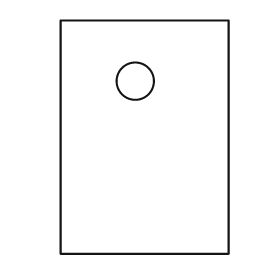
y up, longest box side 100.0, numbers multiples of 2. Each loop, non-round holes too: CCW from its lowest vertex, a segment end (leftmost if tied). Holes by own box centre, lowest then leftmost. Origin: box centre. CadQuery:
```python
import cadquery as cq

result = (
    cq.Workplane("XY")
    .moveTo(-36.0, -50.0)
    .lineTo(36.0, -50.0)
    .lineTo(36.0, 50.0)
    .lineTo(-36.0, 50.0)
    .close()
    .moveTo(-4.0, 24.0)
    .circle(8.0)
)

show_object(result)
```